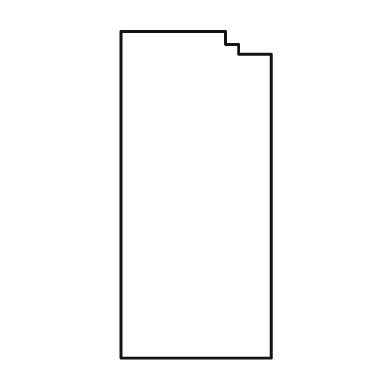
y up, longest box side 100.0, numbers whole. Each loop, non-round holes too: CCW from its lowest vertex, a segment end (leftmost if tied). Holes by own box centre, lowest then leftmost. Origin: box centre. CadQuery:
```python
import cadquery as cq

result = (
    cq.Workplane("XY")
    .moveTo(-23.0, -50.0)
    .lineTo(23.0, -50.0)
    .lineTo(23.0, 43.0)
    .lineTo(13.0, 43.0)
    .lineTo(13.0, 46.0)
    .lineTo(9.0, 46.0)
    .lineTo(9.0, 50.0)
    .lineTo(-23.0, 50.0)
    .close()
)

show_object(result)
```